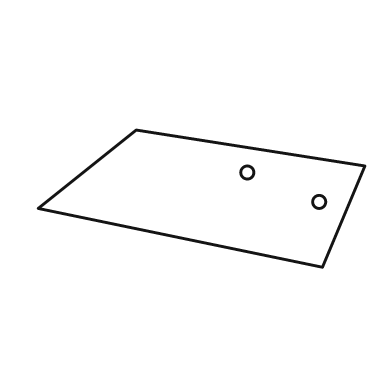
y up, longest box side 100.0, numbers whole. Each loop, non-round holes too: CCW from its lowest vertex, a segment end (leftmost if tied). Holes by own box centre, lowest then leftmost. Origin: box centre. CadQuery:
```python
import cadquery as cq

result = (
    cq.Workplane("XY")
    .moveTo(37.0, -21.0)
    .lineTo(50.0, 10.0)
    .lineTo(-20.0, 21.0)
    .lineTo(-50.0, -3.0)
    .close()
    .moveTo(36.0, -1.0)
    .circle(2.0)
    .moveTo(14.0, 8.0)
    .circle(2.0)
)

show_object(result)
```